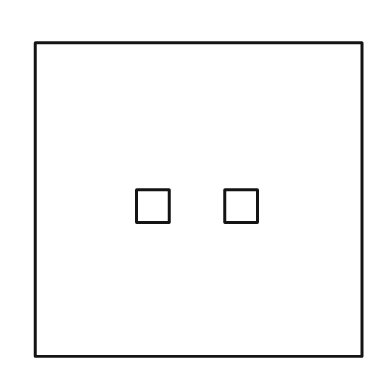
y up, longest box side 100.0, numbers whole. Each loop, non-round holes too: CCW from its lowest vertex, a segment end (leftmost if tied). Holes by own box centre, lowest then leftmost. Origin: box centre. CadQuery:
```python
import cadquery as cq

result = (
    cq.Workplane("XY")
    .moveTo(-50.0, -48.0)
    .lineTo(50.0, -48.0)
    .lineTo(50.0, 48.0)
    .lineTo(-50.0, 48.0)
    .close()
    .moveTo(-19.0, -7.0)
    .lineTo(-9.0, -7.0)
    .lineTo(-9.0, 3.0)
    .lineTo(-19.0, 3.0)
    .close()
    .moveTo(8.0, -7.0)
    .lineTo(18.0, -7.0)
    .lineTo(18.0, 3.0)
    .lineTo(8.0, 3.0)
    .close()
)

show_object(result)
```